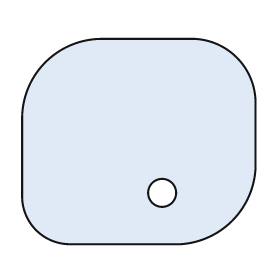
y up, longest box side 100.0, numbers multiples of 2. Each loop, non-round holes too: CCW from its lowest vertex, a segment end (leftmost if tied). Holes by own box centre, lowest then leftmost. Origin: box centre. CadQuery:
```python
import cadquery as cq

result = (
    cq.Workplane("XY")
    .moveTo(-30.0, -44.0)
    .lineTo(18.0, -44.0)
    .threePointArc((40.0, -34.0), (50.0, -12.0))
    .lineTo(50.0, 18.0)
    .threePointArc((42.0, 36.0), (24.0, 44.0))
    .lineTo(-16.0, 44.0)
    .threePointArc((-40.0, 34.0), (-50.0, 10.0))
    .lineTo(-50.0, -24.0)
    .threePointArc((-44.0, -38.0), (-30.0, -44.0))
    .close()
    .moveTo(10.0, -22.0)
    .circle(6.0)
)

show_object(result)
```